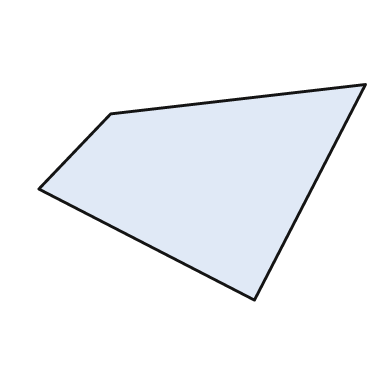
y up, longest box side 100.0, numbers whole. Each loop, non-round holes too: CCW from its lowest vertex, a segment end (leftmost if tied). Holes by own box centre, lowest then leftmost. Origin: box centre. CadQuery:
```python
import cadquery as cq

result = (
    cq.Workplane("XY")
    .moveTo(16.0, -33.0)
    .lineTo(50.0, 33.0)
    .lineTo(-28.0, 24.0)
    .lineTo(-50.0, 1.0)
    .close()
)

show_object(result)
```